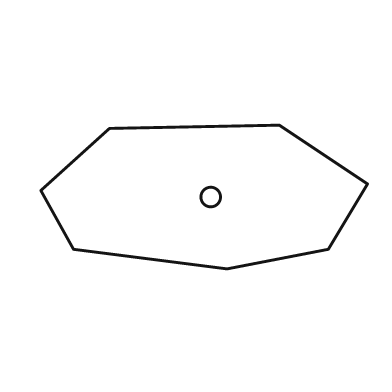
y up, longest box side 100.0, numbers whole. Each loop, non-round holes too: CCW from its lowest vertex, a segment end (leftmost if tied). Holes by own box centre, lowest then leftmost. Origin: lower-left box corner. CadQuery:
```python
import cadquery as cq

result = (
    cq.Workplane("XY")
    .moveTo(57.0, 0.0)
    .lineTo(88.0, 6.0)
    .lineTo(100.0, 26.0)
    .lineTo(73.0, 44.0)
    .lineTo(21.0, 43.0)
    .lineTo(0.0, 24.0)
    .lineTo(10.0, 6.0)
    .close()
    .moveTo(52.0, 22.0)
    .circle(3.0)
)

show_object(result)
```